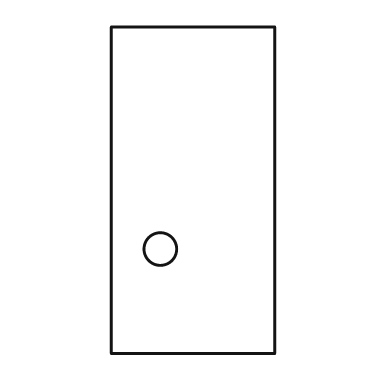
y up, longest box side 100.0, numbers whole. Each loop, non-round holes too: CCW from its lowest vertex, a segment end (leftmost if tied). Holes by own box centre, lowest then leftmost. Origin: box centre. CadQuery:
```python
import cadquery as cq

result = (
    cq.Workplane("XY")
    .moveTo(-25.0, -50.0)
    .lineTo(25.0, -50.0)
    .lineTo(25.0, 50.0)
    .lineTo(-25.0, 50.0)
    .close()
    .moveTo(-10.0, -18.0)
    .circle(5.0)
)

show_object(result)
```